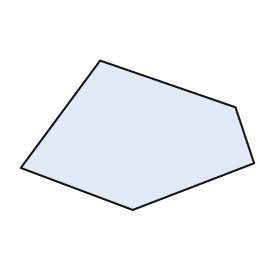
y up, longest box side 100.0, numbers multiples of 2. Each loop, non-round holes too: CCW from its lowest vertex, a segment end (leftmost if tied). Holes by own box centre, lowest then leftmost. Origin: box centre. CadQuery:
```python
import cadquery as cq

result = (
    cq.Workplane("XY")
    .moveTo(-2.0, -32.0)
    .lineTo(50.0, -12.0)
    .lineTo(42.0, 12.0)
    .lineTo(-16.0, 32.0)
    .lineTo(-50.0, -14.0)
    .close()
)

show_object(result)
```